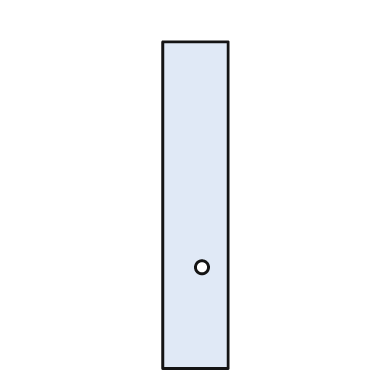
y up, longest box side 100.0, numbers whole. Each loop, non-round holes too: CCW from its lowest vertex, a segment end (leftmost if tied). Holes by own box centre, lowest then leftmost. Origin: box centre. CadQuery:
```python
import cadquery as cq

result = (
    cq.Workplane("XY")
    .moveTo(-10.0, -50.0)
    .lineTo(10.0, -50.0)
    .lineTo(10.0, 50.0)
    .lineTo(-10.0, 50.0)
    .close()
    .moveTo(2.0, -19.0)
    .circle(2.0)
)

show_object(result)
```